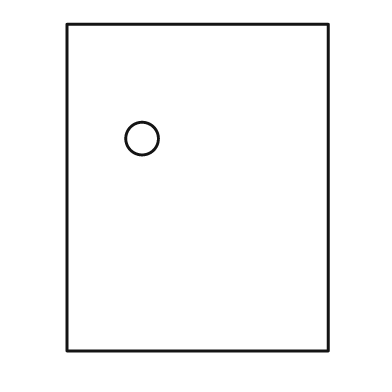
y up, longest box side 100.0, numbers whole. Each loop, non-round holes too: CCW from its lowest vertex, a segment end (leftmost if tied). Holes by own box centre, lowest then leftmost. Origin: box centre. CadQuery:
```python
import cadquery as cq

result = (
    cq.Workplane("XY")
    .moveTo(-40.0, -50.0)
    .lineTo(40.0, -50.0)
    .lineTo(40.0, 50.0)
    .lineTo(-40.0, 50.0)
    .close()
    .moveTo(-17.0, 15.0)
    .circle(5.0)
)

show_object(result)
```